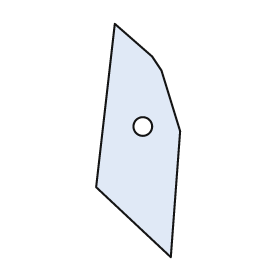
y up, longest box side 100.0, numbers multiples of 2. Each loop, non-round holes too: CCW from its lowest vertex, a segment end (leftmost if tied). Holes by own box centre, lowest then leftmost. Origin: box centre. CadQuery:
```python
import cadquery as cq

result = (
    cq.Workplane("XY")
    .moveTo(14.0, -50.0)
    .lineTo(18.0, 4.0)
    .lineTo(10.0, 30.0)
    .lineTo(6.0, 36.0)
    .lineTo(-10.0, 50.0)
    .lineTo(-18.0, -20.0)
    .close()
    .moveTo(2.0, 6.0)
    .circle(4.0)
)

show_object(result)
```